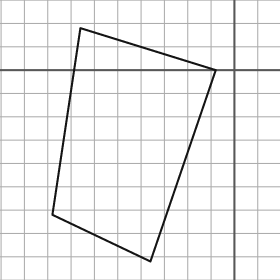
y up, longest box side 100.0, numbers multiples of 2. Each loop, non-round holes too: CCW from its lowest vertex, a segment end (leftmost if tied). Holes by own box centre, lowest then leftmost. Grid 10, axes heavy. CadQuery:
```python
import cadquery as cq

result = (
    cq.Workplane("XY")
    .moveTo(-36.0, -82.0)
    .lineTo(-8.0, 0.0)
    .lineTo(-66.0, 18.0)
    .lineTo(-78.0, -62.0)
    .close()
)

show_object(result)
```